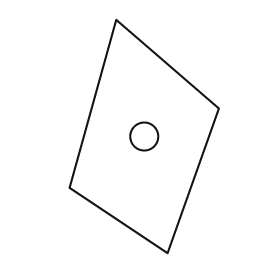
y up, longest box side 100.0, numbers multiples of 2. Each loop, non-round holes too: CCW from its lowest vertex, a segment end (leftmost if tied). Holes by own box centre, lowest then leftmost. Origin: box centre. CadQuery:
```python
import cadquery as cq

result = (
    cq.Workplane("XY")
    .moveTo(10.0, -50.0)
    .lineTo(32.0, 12.0)
    .lineTo(-12.0, 50.0)
    .lineTo(-32.0, -22.0)
    .close()
    .moveTo(0.0, 0.0)
    .circle(6.0)
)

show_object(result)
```